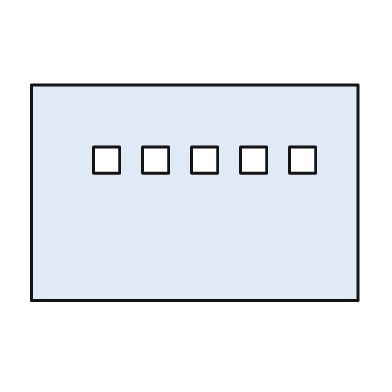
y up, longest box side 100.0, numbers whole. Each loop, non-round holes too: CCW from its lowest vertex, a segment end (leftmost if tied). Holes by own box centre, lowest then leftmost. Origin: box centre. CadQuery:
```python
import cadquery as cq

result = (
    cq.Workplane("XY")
    .moveTo(-50.0, -33.0)
    .lineTo(50.0, -33.0)
    .lineTo(50.0, 33.0)
    .lineTo(-50.0, 33.0)
    .close()
    .moveTo(-31.0, 6.0)
    .lineTo(-23.0, 6.0)
    .lineTo(-23.0, 14.0)
    .lineTo(-31.0, 14.0)
    .close()
    .moveTo(-16.0, 6.0)
    .lineTo(-8.0, 6.0)
    .lineTo(-8.0, 14.0)
    .lineTo(-16.0, 14.0)
    .close()
    .moveTo(-1.0, 6.0)
    .lineTo(7.0, 6.0)
    .lineTo(7.0, 14.0)
    .lineTo(-1.0, 14.0)
    .close()
    .moveTo(14.0, 6.0)
    .lineTo(22.0, 6.0)
    .lineTo(22.0, 14.0)
    .lineTo(14.0, 14.0)
    .close()
    .moveTo(29.0, 6.0)
    .lineTo(37.0, 6.0)
    .lineTo(37.0, 14.0)
    .lineTo(29.0, 14.0)
    .close()
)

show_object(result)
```